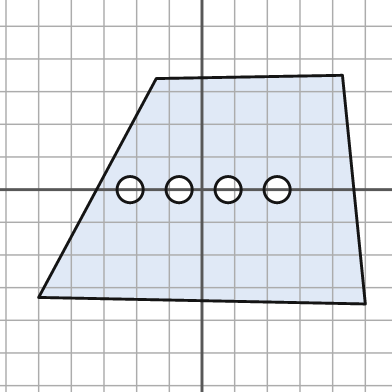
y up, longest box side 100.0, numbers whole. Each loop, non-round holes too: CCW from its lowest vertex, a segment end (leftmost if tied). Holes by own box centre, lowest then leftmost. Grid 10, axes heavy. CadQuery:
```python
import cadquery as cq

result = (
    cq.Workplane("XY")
    .moveTo(50.0, -35.0)
    .lineTo(43.0, 35.0)
    .lineTo(-14.0, 34.0)
    .lineTo(-50.0, -33.0)
    .close()
    .moveTo(-22.0, 0.0)
    .circle(4.0)
    .moveTo(-7.0, 0.0)
    .circle(4.0)
    .moveTo(8.0, 0.0)
    .circle(4.0)
    .moveTo(23.0, 0.0)
    .circle(4.0)
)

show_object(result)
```